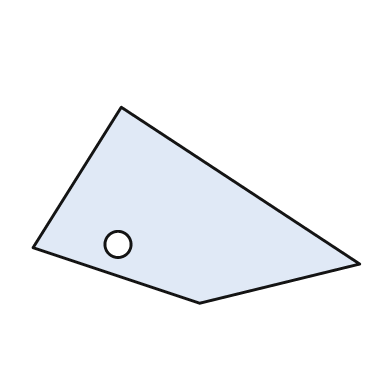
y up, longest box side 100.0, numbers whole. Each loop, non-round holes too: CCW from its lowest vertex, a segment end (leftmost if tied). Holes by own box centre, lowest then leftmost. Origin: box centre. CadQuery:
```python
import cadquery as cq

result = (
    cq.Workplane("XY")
    .moveTo(1.0, -30.0)
    .lineTo(50.0, -18.0)
    .lineTo(-23.0, 30.0)
    .lineTo(-50.0, -13.0)
    .close()
    .moveTo(-24.0, -12.0)
    .circle(4.0)
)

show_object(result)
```